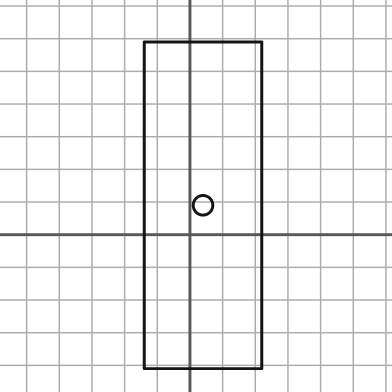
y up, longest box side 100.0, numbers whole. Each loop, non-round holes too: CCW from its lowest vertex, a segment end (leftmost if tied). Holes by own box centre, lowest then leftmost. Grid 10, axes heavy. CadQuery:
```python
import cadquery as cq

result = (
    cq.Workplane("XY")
    .moveTo(-14.0, -41.0)
    .lineTo(22.0, -41.0)
    .lineTo(22.0, 59.0)
    .lineTo(-14.0, 59.0)
    .close()
    .moveTo(4.0, 9.0)
    .circle(3.0)
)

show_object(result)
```